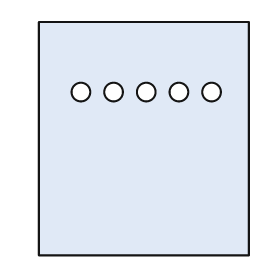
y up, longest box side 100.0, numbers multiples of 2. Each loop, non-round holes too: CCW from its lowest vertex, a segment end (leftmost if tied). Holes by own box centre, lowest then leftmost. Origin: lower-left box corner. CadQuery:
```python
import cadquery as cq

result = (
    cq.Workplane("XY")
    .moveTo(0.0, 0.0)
    .lineTo(90.0, 0.0)
    .lineTo(90.0, 100.0)
    .lineTo(0.0, 100.0)
    .close()
    .moveTo(18.0, 70.0)
    .circle(4.0)
    .moveTo(32.0, 70.0)
    .circle(4.0)
    .moveTo(46.0, 70.0)
    .circle(4.0)
    .moveTo(60.0, 70.0)
    .circle(4.0)
    .moveTo(74.0, 70.0)
    .circle(4.0)
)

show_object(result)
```